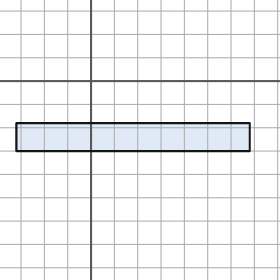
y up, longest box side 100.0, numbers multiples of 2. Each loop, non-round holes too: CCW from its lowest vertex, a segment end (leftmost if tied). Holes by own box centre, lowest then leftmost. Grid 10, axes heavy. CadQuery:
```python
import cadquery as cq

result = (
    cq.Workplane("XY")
    .moveTo(-32.0, -30.0)
    .lineTo(68.0, -30.0)
    .lineTo(68.0, -18.0)
    .lineTo(-32.0, -18.0)
    .close()
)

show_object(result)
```